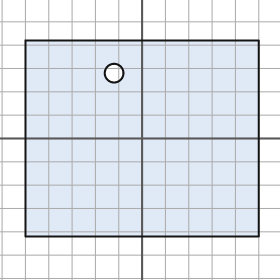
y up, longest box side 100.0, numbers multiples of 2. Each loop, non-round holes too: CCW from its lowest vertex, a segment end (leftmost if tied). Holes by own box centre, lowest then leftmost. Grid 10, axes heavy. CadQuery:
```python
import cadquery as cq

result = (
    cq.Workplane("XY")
    .moveTo(-50.0, -42.0)
    .lineTo(50.0, -42.0)
    .lineTo(50.0, 42.0)
    .lineTo(-50.0, 42.0)
    .close()
    .moveTo(-12.0, 28.0)
    .circle(4.0)
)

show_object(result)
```